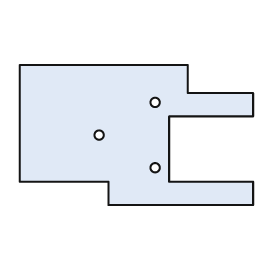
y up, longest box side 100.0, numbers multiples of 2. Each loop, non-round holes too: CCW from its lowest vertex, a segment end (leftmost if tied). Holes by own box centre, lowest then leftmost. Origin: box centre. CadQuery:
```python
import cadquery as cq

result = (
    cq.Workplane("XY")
    .moveTo(-12.0, -30.0)
    .lineTo(50.0, -30.0)
    .lineTo(50.0, -20.0)
    .lineTo(14.0, -20.0)
    .lineTo(14.0, 8.0)
    .lineTo(50.0, 8.0)
    .lineTo(50.0, 18.0)
    .lineTo(22.0, 18.0)
    .lineTo(22.0, 30.0)
    .lineTo(-50.0, 30.0)
    .lineTo(-50.0, -20.0)
    .lineTo(-12.0, -20.0)
    .close()
    .moveTo(8.0, -14.0)
    .circle(2.0)
    .moveTo(-16.0, 0.0)
    .circle(2.0)
    .moveTo(8.0, 14.0)
    .circle(2.0)
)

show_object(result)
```